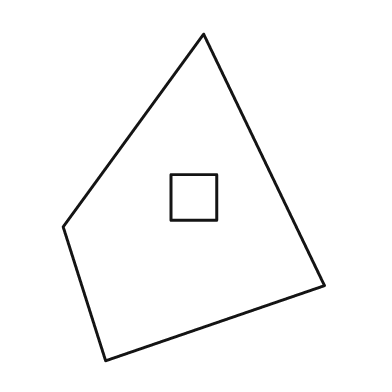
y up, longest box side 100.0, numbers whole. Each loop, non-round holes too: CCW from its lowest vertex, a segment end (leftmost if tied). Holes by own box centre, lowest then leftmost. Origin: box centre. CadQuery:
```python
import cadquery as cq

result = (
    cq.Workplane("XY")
    .moveTo(-27.0, -50.0)
    .lineTo(40.0, -27.0)
    .lineTo(3.0, 50.0)
    .lineTo(-40.0, -9.0)
    .close()
    .moveTo(-7.0, -7.0)
    .lineTo(7.0, -7.0)
    .lineTo(7.0, 7.0)
    .lineTo(-7.0, 7.0)
    .close()
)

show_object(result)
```